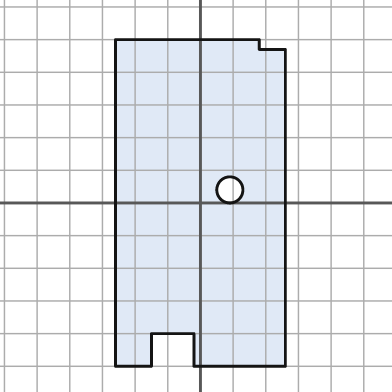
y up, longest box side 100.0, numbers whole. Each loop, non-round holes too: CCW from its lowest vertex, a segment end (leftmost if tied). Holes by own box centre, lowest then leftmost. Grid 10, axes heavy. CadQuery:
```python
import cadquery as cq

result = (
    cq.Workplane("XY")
    .moveTo(-26.0, -50.0)
    .lineTo(-15.0, -50.0)
    .lineTo(-15.0, -40.0)
    .lineTo(-2.0, -40.0)
    .lineTo(-2.0, -50.0)
    .lineTo(26.0, -50.0)
    .lineTo(26.0, 47.0)
    .lineTo(18.0, 47.0)
    .lineTo(18.0, 50.0)
    .lineTo(-26.0, 50.0)
    .close()
    .moveTo(9.0, 4.0)
    .circle(4.0)
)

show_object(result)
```